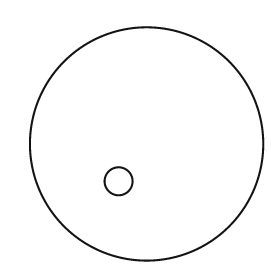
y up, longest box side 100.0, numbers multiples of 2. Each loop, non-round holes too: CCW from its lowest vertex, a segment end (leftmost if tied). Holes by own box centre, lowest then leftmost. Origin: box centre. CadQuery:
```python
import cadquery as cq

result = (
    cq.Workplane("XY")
    .moveTo(0.0, 0.0)
    .circle(50.0)
    .moveTo(-12.0, -16.0)
    .circle(6.0)
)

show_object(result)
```